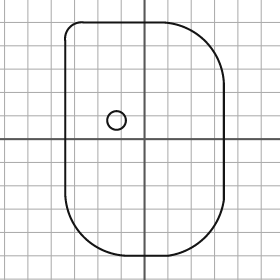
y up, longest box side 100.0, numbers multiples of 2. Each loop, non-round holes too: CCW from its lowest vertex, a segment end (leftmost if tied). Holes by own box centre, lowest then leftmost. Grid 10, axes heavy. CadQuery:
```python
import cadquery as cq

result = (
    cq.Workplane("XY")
    .moveTo(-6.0, -50.0)
    .lineTo(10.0, -50.0)
    .threePointArc((26.0, -42.0), (34.0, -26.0))
    .lineTo(34.0, 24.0)
    .threePointArc((26.0, 42.0), (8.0, 50.0))
    .lineTo(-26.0, 50.0)
    .threePointArc((-32.0, 48.0), (-34.0, 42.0))
    .lineTo(-34.0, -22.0)
    .threePointArc((-26.0, -42.0), (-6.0, -50.0))
    .close()
    .moveTo(-12.0, 8.0)
    .circle(4.0)
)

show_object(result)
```